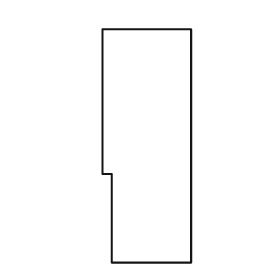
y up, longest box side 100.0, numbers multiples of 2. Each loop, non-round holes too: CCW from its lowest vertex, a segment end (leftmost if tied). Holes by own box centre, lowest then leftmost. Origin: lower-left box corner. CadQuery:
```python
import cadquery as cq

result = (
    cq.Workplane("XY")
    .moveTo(4.0, 0.0)
    .lineTo(38.0, 0.0)
    .lineTo(38.0, 100.0)
    .lineTo(0.0, 100.0)
    .lineTo(0.0, 38.0)
    .lineTo(4.0, 38.0)
    .close()
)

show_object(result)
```